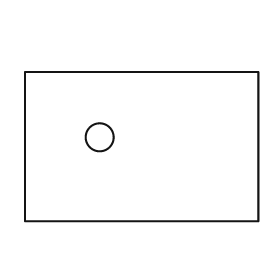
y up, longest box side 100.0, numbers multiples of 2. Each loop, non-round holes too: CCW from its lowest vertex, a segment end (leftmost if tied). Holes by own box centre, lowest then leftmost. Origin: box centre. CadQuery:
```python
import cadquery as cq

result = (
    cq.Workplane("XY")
    .moveTo(-50.0, -32.0)
    .lineTo(50.0, -32.0)
    .lineTo(50.0, 32.0)
    .lineTo(-50.0, 32.0)
    .close()
    .moveTo(-18.0, 4.0)
    .circle(6.0)
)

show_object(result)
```